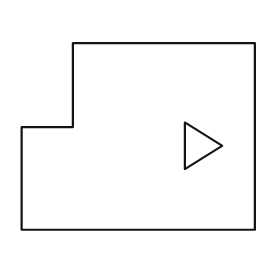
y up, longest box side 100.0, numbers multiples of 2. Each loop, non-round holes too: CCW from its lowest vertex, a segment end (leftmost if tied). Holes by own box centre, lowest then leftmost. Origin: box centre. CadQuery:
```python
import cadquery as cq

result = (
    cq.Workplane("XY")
    .moveTo(-50.0, -40.0)
    .lineTo(50.0, -40.0)
    .lineTo(50.0, 40.0)
    .lineTo(-28.0, 40.0)
    .lineTo(-28.0, 4.0)
    .lineTo(-50.0, 4.0)
    .close()
    .moveTo(20.0, -14.0)
    .lineTo(36.0, -4.0)
    .lineTo(20.0, 6.0)
    .close()
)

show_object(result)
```